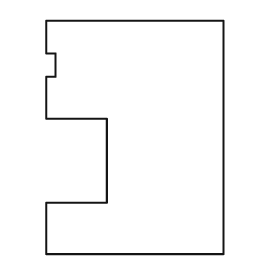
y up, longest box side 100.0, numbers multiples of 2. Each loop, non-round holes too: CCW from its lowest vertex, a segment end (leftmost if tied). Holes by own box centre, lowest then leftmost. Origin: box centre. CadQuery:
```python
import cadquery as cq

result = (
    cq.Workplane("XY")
    .moveTo(-38.0, -50.0)
    .lineTo(38.0, -50.0)
    .lineTo(38.0, 50.0)
    .lineTo(-38.0, 50.0)
    .lineTo(-38.0, 36.0)
    .lineTo(-34.0, 36.0)
    .lineTo(-34.0, 26.0)
    .lineTo(-38.0, 26.0)
    .lineTo(-38.0, 8.0)
    .lineTo(-12.0, 8.0)
    .lineTo(-12.0, -28.0)
    .lineTo(-38.0, -28.0)
    .close()
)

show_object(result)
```